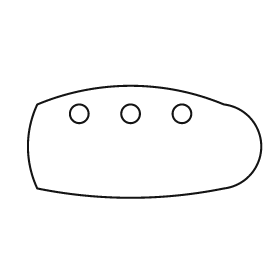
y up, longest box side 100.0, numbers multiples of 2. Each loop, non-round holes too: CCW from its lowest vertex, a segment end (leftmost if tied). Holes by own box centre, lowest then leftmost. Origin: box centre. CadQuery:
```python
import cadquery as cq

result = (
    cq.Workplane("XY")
    .moveTo(-46.0, -20.0)
    .threePointArc((-6.0, -24.0), (34.0, -20.0))
    .threePointArc((50.0, -2.0), (34.0, 16.0))
    .threePointArc((-6.0, 24.0), (-46.0, 16.0))
    .threePointArc((-50.0, -2.0), (-46.0, -20.0))
    .close()
    .moveTo(-28.0, 12.0)
    .circle(4.0)
    .moveTo(-6.0, 12.0)
    .circle(4.0)
    .moveTo(16.0, 12.0)
    .circle(4.0)
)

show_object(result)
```